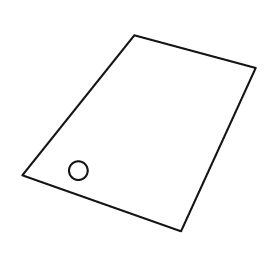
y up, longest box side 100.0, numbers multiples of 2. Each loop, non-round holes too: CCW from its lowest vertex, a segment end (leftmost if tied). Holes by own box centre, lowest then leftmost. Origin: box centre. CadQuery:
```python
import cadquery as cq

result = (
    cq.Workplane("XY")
    .moveTo(18.0, -42.0)
    .lineTo(50.0, 28.0)
    .lineTo(-2.0, 42.0)
    .lineTo(-50.0, -18.0)
    .close()
    .moveTo(-26.0, -16.0)
    .circle(4.0)
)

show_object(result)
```